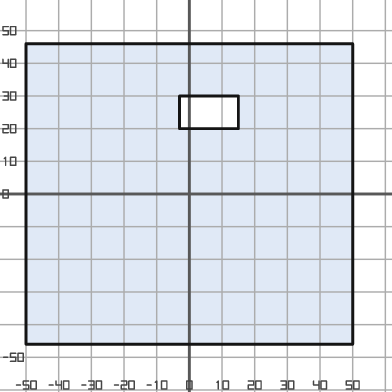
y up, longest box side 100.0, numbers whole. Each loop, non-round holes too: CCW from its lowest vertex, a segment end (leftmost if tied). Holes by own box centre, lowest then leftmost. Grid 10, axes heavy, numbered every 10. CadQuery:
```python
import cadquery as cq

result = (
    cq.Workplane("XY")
    .moveTo(-50.0, -46.0)
    .lineTo(50.0, -46.0)
    .lineTo(50.0, 46.0)
    .lineTo(-50.0, 46.0)
    .close()
    .moveTo(-3.0, 20.0)
    .lineTo(15.0, 20.0)
    .lineTo(15.0, 30.0)
    .lineTo(-3.0, 30.0)
    .close()
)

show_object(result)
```